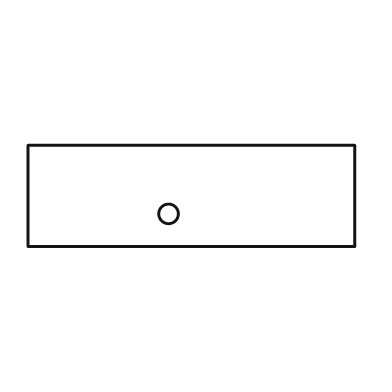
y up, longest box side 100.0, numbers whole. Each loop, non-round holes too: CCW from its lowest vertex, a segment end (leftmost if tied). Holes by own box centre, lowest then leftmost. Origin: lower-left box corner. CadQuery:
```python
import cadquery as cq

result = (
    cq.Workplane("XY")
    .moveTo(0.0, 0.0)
    .lineTo(100.0, 0.0)
    .lineTo(100.0, 31.0)
    .lineTo(0.0, 31.0)
    .close()
    .moveTo(43.0, 10.0)
    .circle(3.0)
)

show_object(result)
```